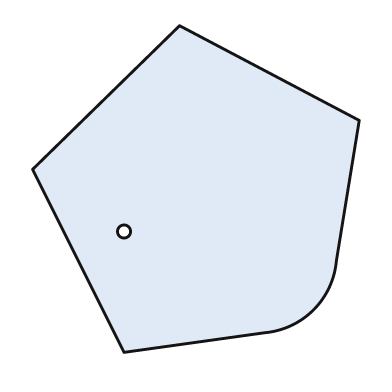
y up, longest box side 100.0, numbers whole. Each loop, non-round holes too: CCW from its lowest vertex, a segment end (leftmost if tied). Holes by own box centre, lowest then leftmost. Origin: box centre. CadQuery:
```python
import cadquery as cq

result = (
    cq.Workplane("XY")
    .moveTo(-22.0, -50.0)
    .lineTo(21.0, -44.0)
    .threePointArc((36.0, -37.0), (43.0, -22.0))
    .lineTo(50.0, 21.0)
    .lineTo(-5.0, 50.0)
    .lineTo(-50.0, 6.0)
    .close()
    .moveTo(-22.0, -13.0)
    .circle(2.0)
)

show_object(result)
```